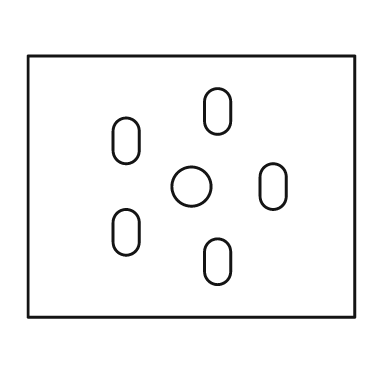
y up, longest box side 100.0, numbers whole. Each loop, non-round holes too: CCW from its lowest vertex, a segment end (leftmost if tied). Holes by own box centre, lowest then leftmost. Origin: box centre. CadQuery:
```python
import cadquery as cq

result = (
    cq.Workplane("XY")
    .moveTo(-50.0, -40.0)
    .lineTo(50.0, -40.0)
    .lineTo(50.0, 40.0)
    .lineTo(-50.0, 40.0)
    .close()
    .moveTo(4.0, -26.0)
    .threePointArc((8.0, -30.0), (12.0, -26.0))
    .lineTo(12.0, -20.0)
    .threePointArc((8.0, -16.0), (4.0, -20.0))
    .close()
    .moveTo(-24.0, -17.0)
    .threePointArc((-20.0, -21.0), (-16.0, -17.0))
    .lineTo(-16.0, -11.0)
    .threePointArc((-20.0, -7.0), (-24.0, -11.0))
    .close()
    .moveTo(0.0, 0.0)
    .circle(6.0)
    .moveTo(21.0, -3.0)
    .threePointArc((25.0, -7.0), (29.0, -3.0))
    .lineTo(29.0, 3.0)
    .threePointArc((25.0, 7.0), (21.0, 3.0))
    .close()
    .moveTo(-24.0, 11.0)
    .threePointArc((-20.0, 7.0), (-16.0, 11.0))
    .lineTo(-16.0, 17.0)
    .threePointArc((-20.0, 21.0), (-24.0, 17.0))
    .close()
    .moveTo(4.0, 20.0)
    .threePointArc((8.0, 16.0), (12.0, 20.0))
    .lineTo(12.0, 26.0)
    .threePointArc((8.0, 30.0), (4.0, 26.0))
    .close()
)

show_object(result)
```